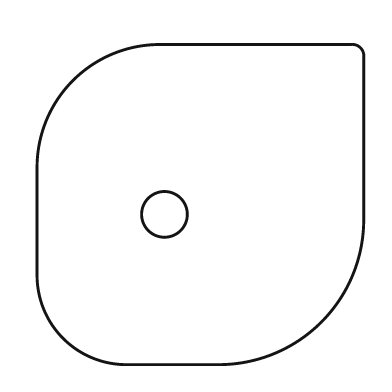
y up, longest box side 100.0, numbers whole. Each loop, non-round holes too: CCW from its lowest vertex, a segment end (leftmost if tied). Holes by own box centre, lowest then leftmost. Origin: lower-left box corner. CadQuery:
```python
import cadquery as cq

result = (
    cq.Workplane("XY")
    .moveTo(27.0, 0.0)
    .lineTo(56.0, 0.0)
    .threePointArc((87.0, 13.0), (100.0, 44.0))
    .lineTo(100.0, 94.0)
    .threePointArc((99.0, 97.0), (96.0, 98.0))
    .lineTo(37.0, 98.0)
    .threePointArc((11.0, 87.0), (0.0, 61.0))
    .lineTo(0.0, 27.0)
    .threePointArc((8.0, 8.0), (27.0, 0.0))
    .close()
    .moveTo(39.0, 46.0)
    .circle(7.0)
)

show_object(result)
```